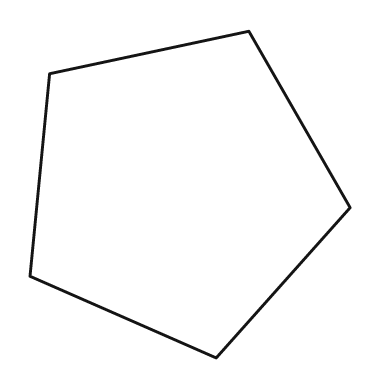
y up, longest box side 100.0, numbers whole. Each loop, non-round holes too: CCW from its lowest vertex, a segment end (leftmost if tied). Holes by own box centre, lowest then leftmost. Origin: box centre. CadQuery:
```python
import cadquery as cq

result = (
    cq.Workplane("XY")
    .moveTo(8.0, -50.0)
    .lineTo(49.0, -4.0)
    .lineTo(18.0, 50.0)
    .lineTo(-43.0, 37.0)
    .lineTo(-49.0, -25.0)
    .close()
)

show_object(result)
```